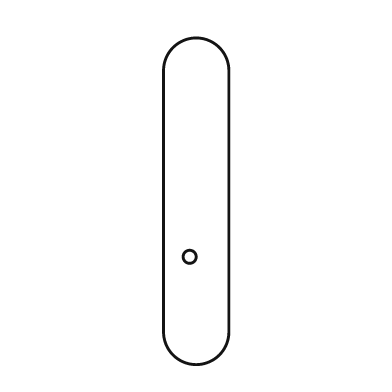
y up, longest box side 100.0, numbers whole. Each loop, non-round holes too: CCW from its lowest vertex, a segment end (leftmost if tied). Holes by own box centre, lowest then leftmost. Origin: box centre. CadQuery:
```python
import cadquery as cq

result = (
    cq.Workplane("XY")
    .moveTo(-10.0, -40.0)
    .threePointArc((0.0, -50.0), (10.0, -40.0))
    .lineTo(10.0, 40.0)
    .threePointArc((0.0, 50.0), (-10.0, 40.0))
    .close()
    .moveTo(-2.0, -17.0)
    .circle(2.0)
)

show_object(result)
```